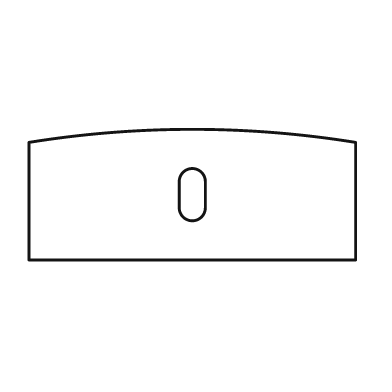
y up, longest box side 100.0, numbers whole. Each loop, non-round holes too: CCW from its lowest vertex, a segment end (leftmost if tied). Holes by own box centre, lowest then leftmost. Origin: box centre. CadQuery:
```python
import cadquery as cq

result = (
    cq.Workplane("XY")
    .moveTo(-50.0, -20.0)
    .lineTo(50.0, -20.0)
    .lineTo(50.0, 16.0)
    .threePointArc((0.0, 20.0), (-50.0, 16.0))
    .close()
    .moveTo(-4.0, -4.0)
    .threePointArc((0.0, -8.0), (4.0, -4.0))
    .lineTo(4.0, 4.0)
    .threePointArc((0.0, 8.0), (-4.0, 4.0))
    .close()
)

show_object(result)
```